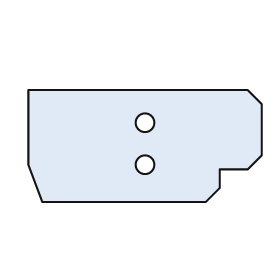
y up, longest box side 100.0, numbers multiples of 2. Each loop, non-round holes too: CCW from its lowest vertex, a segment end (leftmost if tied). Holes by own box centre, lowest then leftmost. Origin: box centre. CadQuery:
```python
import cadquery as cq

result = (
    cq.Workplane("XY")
    .moveTo(-44.0, -24.0)
    .lineTo(26.0, -24.0)
    .lineTo(32.0, -18.0)
    .lineTo(32.0, -10.0)
    .lineTo(44.0, -10.0)
    .lineTo(50.0, -4.0)
    .lineTo(50.0, 18.0)
    .lineTo(44.0, 24.0)
    .lineTo(-50.0, 24.0)
    .lineTo(-50.0, -8.0)
    .close()
    .moveTo(0.0, -8.0)
    .circle(4.0)
    .moveTo(0.0, 10.0)
    .circle(4.0)
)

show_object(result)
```